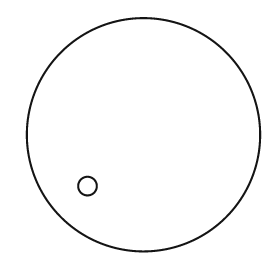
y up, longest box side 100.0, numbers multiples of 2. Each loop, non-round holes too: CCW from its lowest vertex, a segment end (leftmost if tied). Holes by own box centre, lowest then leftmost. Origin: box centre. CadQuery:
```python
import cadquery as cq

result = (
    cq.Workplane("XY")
    .moveTo(0.0, 0.0)
    .circle(50.0)
    .moveTo(-24.0, -22.0)
    .circle(4.0)
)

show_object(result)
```